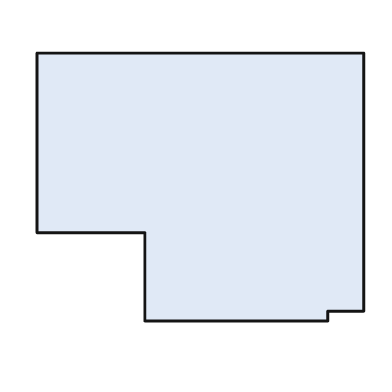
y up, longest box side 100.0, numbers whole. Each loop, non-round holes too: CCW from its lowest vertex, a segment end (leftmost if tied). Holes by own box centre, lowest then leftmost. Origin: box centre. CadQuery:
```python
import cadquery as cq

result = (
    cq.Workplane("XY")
    .moveTo(-17.0, -41.0)
    .lineTo(39.0, -41.0)
    .lineTo(39.0, -38.0)
    .lineTo(50.0, -38.0)
    .lineTo(50.0, 41.0)
    .lineTo(-50.0, 41.0)
    .lineTo(-50.0, -14.0)
    .lineTo(-17.0, -14.0)
    .close()
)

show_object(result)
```